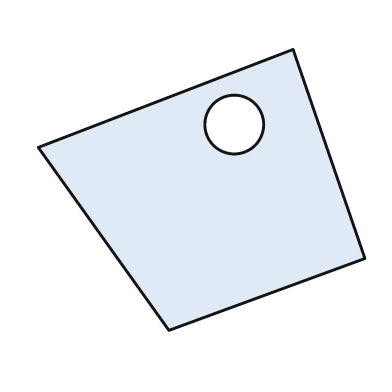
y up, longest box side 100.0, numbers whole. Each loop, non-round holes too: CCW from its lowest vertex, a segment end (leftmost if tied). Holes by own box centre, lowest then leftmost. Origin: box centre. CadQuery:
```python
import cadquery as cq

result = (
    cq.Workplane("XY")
    .moveTo(-10.0, -43.0)
    .lineTo(50.0, -21.0)
    .lineTo(28.0, 43.0)
    .lineTo(-50.0, 13.0)
    .close()
    .moveTo(10.0, 20.0)
    .circle(9.0)
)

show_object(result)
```